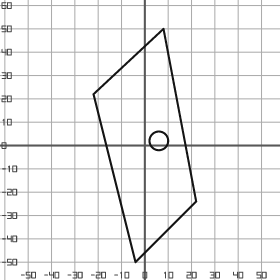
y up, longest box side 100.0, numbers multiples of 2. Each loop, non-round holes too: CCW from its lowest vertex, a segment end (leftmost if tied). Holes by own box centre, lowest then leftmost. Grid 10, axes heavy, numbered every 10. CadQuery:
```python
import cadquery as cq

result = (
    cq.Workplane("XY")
    .moveTo(-4.0, -50.0)
    .lineTo(22.0, -24.0)
    .lineTo(8.0, 50.0)
    .lineTo(-22.0, 22.0)
    .close()
    .moveTo(6.0, 2.0)
    .circle(4.0)
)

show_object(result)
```